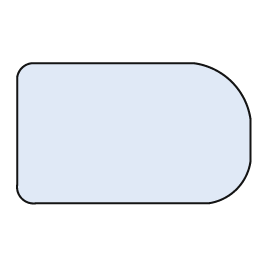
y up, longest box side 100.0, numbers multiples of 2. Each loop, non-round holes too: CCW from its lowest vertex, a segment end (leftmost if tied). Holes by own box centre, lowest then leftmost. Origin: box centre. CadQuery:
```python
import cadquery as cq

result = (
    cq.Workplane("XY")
    .moveTo(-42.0, -30.0)
    .lineTo(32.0, -30.0)
    .threePointArc((44.0, -24.0), (50.0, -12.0))
    .lineTo(50.0, 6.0)
    .threePointArc((42.0, 22.0), (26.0, 30.0))
    .lineTo(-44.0, 30.0)
    .threePointArc((-48.0, 28.0), (-50.0, 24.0))
    .lineTo(-50.0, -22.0)
    .threePointArc((-48.0, -28.0), (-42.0, -30.0))
    .close()
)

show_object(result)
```